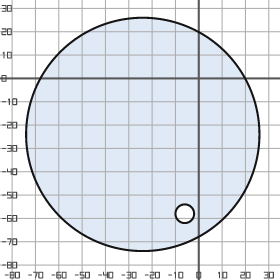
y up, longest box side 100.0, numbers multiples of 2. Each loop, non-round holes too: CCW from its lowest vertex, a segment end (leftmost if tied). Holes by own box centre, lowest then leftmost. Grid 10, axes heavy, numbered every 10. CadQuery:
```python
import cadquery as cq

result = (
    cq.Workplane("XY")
    .moveTo(-24.0, -24.0)
    .circle(50.0)
    .moveTo(-6.0, -58.0)
    .circle(4.0)
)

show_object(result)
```